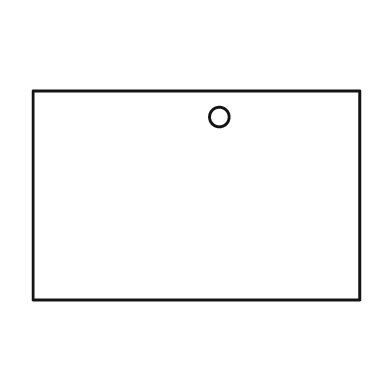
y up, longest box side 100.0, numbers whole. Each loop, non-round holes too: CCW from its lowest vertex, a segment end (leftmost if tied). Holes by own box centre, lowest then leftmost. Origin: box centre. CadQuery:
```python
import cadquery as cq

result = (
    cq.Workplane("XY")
    .moveTo(-50.0, -32.0)
    .lineTo(50.0, -32.0)
    .lineTo(50.0, 32.0)
    .lineTo(-50.0, 32.0)
    .close()
    .moveTo(7.0, 24.0)
    .circle(3.0)
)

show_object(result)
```